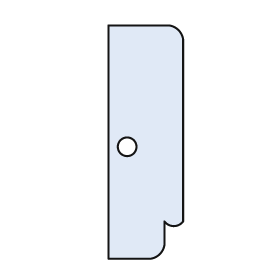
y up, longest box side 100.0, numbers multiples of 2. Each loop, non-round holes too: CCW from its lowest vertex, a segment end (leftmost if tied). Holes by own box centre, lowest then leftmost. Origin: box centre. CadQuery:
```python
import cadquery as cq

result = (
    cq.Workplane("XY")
    .moveTo(-16.0, -50.0)
    .lineTo(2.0, -50.0)
    .threePointArc((6.0, -48.0), (8.0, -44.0))
    .lineTo(8.0, -34.0)
    .threePointArc((12.0, -36.0), (16.0, -34.0))
    .lineTo(16.0, 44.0)
    .threePointArc((14.0, 48.0), (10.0, 50.0))
    .lineTo(-16.0, 50.0)
    .close()
    .moveTo(-8.0, -2.0)
    .circle(4.0)
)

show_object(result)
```